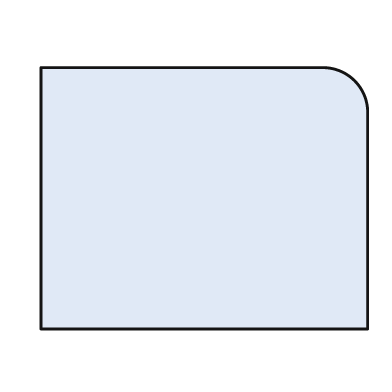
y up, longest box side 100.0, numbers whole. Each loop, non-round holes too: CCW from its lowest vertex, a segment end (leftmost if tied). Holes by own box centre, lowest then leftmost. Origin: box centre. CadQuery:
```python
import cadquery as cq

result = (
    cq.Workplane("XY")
    .moveTo(-50.0, -40.0)
    .lineTo(50.0, -40.0)
    .lineTo(50.0, 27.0)
    .threePointArc((46.0, 36.0), (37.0, 40.0))
    .lineTo(-50.0, 40.0)
    .close()
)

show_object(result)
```